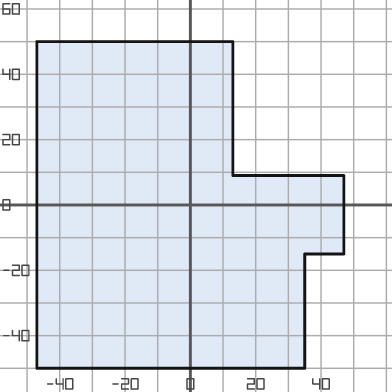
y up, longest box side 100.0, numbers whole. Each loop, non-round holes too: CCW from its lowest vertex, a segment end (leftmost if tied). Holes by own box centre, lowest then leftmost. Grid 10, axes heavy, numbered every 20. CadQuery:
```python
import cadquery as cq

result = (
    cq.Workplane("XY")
    .moveTo(-47.0, -50.0)
    .lineTo(35.0, -50.0)
    .lineTo(35.0, -15.0)
    .lineTo(47.0, -15.0)
    .lineTo(47.0, 9.0)
    .lineTo(13.0, 9.0)
    .lineTo(13.0, 50.0)
    .lineTo(-47.0, 50.0)
    .close()
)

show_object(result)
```